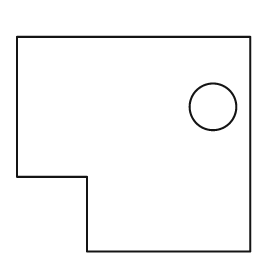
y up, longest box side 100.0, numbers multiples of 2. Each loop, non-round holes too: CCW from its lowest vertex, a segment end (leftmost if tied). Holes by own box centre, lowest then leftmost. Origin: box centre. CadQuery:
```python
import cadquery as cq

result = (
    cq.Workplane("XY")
    .moveTo(-20.0, -46.0)
    .lineTo(50.0, -46.0)
    .lineTo(50.0, 46.0)
    .lineTo(-50.0, 46.0)
    .lineTo(-50.0, -14.0)
    .lineTo(-20.0, -14.0)
    .close()
    .moveTo(34.0, 16.0)
    .circle(10.0)
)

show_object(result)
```